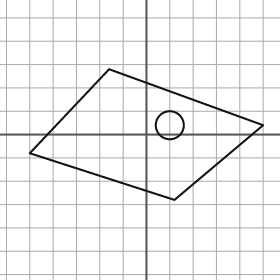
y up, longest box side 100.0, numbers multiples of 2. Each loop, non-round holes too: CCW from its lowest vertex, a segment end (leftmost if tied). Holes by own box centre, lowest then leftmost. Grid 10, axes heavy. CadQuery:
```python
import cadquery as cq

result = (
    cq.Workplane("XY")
    .moveTo(12.0, -28.0)
    .lineTo(50.0, 4.0)
    .lineTo(-16.0, 28.0)
    .lineTo(-50.0, -8.0)
    .close()
    .moveTo(10.0, 4.0)
    .circle(6.0)
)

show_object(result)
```